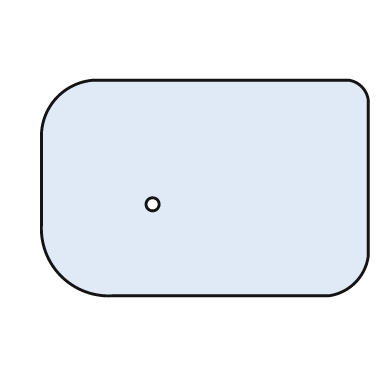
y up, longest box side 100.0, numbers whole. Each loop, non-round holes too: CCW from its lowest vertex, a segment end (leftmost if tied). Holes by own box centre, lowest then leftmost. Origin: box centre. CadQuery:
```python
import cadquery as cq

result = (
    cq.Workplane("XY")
    .moveTo(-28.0, -33.0)
    .lineTo(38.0, -33.0)
    .threePointArc((46.0, -29.0), (50.0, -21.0))
    .lineTo(50.0, 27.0)
    .threePointArc((48.0, 31.0), (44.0, 33.0))
    .lineTo(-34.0, 33.0)
    .threePointArc((-45.0, 28.0), (-50.0, 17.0))
    .lineTo(-50.0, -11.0)
    .threePointArc((-44.0, -27.0), (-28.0, -33.0))
    .close()
    .moveTo(-16.0, -5.0)
    .circle(2.0)
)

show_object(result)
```